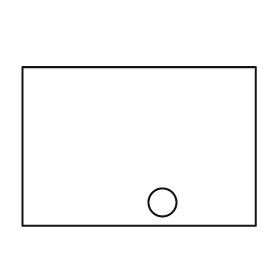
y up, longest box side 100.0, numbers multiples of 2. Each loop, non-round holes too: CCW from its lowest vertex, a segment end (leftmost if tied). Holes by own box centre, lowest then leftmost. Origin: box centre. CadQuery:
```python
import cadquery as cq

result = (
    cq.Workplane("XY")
    .moveTo(-50.0, -34.0)
    .lineTo(50.0, -34.0)
    .lineTo(50.0, 34.0)
    .lineTo(-50.0, 34.0)
    .close()
    .moveTo(10.0, -24.0)
    .circle(6.0)
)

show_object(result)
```